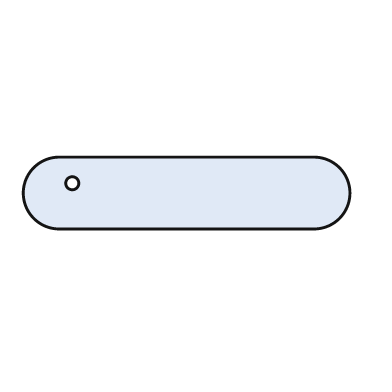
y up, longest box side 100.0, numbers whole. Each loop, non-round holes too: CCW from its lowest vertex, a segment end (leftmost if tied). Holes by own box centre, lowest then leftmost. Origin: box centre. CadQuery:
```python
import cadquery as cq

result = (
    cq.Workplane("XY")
    .moveTo(-39.0, -11.0)
    .lineTo(39.0, -11.0)
    .threePointArc((50.0, 0.0), (39.0, 11.0))
    .lineTo(-39.0, 11.0)
    .threePointArc((-50.0, 0.0), (-39.0, -11.0))
    .close()
    .moveTo(-35.0, 3.0)
    .circle(2.0)
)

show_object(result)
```